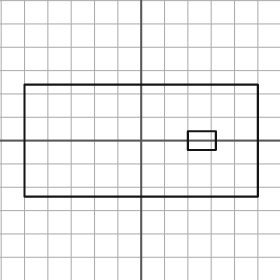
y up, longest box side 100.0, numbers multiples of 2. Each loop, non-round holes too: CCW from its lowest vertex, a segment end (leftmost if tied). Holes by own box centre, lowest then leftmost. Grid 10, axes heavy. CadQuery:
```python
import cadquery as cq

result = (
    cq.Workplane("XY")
    .moveTo(-50.0, -24.0)
    .lineTo(50.0, -24.0)
    .lineTo(50.0, 24.0)
    .lineTo(-50.0, 24.0)
    .close()
    .moveTo(20.0, -4.0)
    .lineTo(32.0, -4.0)
    .lineTo(32.0, 4.0)
    .lineTo(20.0, 4.0)
    .close()
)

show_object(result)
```